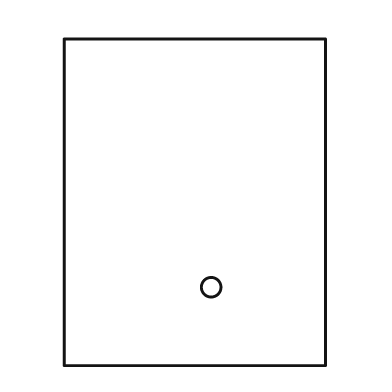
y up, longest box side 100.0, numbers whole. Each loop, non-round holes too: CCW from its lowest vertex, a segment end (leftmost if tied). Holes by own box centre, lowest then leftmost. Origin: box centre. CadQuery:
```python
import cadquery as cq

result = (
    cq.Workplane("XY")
    .moveTo(-40.0, -50.0)
    .lineTo(40.0, -50.0)
    .lineTo(40.0, 50.0)
    .lineTo(-40.0, 50.0)
    .close()
    .moveTo(5.0, -26.0)
    .circle(3.0)
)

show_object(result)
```